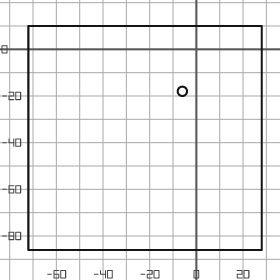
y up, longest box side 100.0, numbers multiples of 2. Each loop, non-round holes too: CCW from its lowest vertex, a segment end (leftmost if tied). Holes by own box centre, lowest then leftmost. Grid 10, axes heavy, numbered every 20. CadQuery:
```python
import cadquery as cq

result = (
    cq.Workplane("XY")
    .moveTo(-72.0, -86.0)
    .lineTo(28.0, -86.0)
    .lineTo(28.0, 10.0)
    .lineTo(-72.0, 10.0)
    .close()
    .moveTo(-6.0, -18.0)
    .circle(2.0)
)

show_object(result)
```